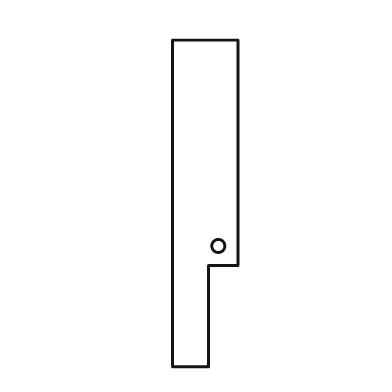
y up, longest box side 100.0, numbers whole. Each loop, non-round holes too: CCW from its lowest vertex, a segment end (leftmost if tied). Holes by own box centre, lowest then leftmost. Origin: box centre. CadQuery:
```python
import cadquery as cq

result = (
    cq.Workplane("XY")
    .moveTo(-10.0, -50.0)
    .lineTo(1.0, -50.0)
    .lineTo(1.0, -19.0)
    .lineTo(10.0, -19.0)
    .lineTo(10.0, 50.0)
    .lineTo(-10.0, 50.0)
    .close()
    .moveTo(4.0, -13.0)
    .circle(2.0)
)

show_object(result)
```